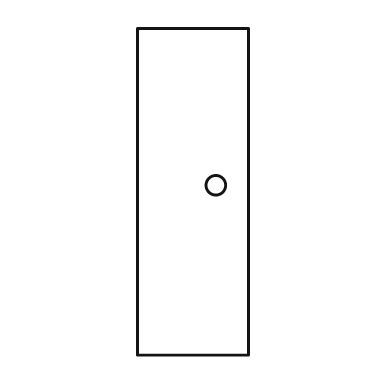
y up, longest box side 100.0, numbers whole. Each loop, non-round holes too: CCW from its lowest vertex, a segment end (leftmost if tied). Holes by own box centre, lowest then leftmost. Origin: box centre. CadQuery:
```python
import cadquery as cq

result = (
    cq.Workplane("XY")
    .moveTo(-17.0, -50.0)
    .lineTo(17.0, -50.0)
    .lineTo(17.0, 50.0)
    .lineTo(-17.0, 50.0)
    .close()
    .moveTo(7.0, 2.0)
    .circle(3.0)
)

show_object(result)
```